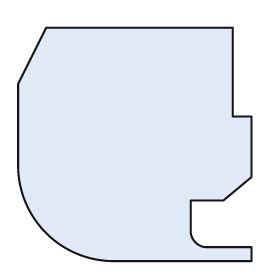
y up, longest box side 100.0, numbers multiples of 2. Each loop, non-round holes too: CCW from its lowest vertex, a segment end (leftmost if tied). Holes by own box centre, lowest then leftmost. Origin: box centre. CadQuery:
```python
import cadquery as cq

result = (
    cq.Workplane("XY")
    .moveTo(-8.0, -50.0)
    .lineTo(50.0, -50.0)
    .lineTo(50.0, -44.0)
    .lineTo(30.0, -44.0)
    .threePointArc((26.0, -42.0), (24.0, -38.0))
    .lineTo(24.0, -24.0)
    .lineTo(38.0, -24.0)
    .lineTo(50.0, -14.0)
    .lineTo(50.0, 12.0)
    .lineTo(42.0, 12.0)
    .lineTo(42.0, 50.0)
    .lineTo(-38.0, 50.0)
    .lineTo(-50.0, 26.0)
    .lineTo(-50.0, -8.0)
    .threePointArc((-38.0, -38.0), (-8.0, -50.0))
    .close()
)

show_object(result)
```